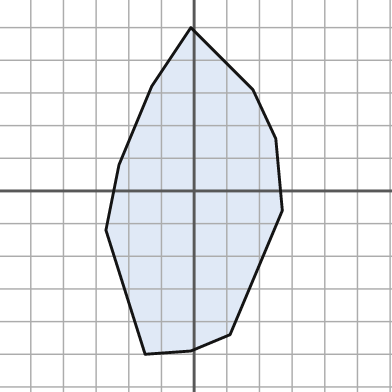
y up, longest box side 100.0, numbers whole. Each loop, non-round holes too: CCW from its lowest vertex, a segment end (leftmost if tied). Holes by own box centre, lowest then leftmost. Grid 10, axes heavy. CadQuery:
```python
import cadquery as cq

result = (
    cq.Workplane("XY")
    .moveTo(-15.0, -50.0)
    .lineTo(-1.0, -49.0)
    .lineTo(11.0, -44.0)
    .lineTo(27.0, -6.0)
    .lineTo(25.0, 16.0)
    .lineTo(18.0, 31.0)
    .lineTo(-1.0, 50.0)
    .lineTo(-13.0, 32.0)
    .lineTo(-23.0, 8.0)
    .lineTo(-27.0, -12.0)
    .close()
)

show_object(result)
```